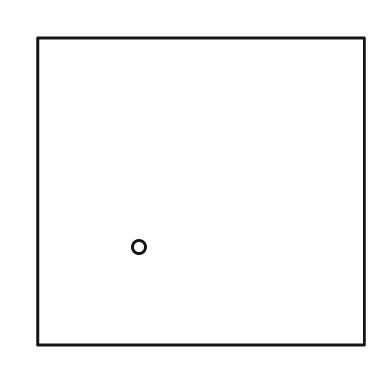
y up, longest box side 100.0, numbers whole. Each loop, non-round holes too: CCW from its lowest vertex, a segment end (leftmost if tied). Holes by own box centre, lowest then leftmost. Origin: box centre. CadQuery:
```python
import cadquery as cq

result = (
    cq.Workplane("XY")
    .moveTo(-50.0, -47.0)
    .lineTo(50.0, -47.0)
    .lineTo(50.0, 47.0)
    .lineTo(-50.0, 47.0)
    .close()
    .moveTo(-19.0, -17.0)
    .circle(2.0)
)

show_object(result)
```